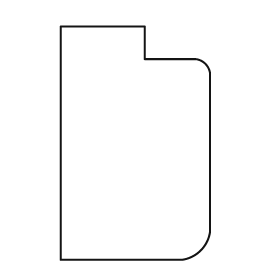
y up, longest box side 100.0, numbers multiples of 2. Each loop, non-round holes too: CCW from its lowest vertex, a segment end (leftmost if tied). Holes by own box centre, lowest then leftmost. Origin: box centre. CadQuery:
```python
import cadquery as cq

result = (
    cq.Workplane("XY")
    .moveTo(-32.0, -50.0)
    .lineTo(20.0, -50.0)
    .threePointArc((28.0, -46.0), (32.0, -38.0))
    .lineTo(32.0, 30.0)
    .threePointArc((30.0, 34.0), (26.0, 36.0))
    .lineTo(4.0, 36.0)
    .lineTo(4.0, 50.0)
    .lineTo(-32.0, 50.0)
    .close()
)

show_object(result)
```